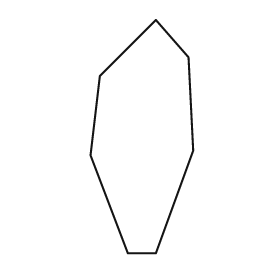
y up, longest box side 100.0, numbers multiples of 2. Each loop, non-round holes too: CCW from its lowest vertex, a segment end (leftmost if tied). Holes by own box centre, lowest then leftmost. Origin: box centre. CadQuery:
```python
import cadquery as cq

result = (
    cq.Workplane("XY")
    .moveTo(-6.0, -50.0)
    .lineTo(6.0, -50.0)
    .lineTo(22.0, -6.0)
    .lineTo(20.0, 34.0)
    .lineTo(6.0, 50.0)
    .lineTo(-18.0, 26.0)
    .lineTo(-22.0, -8.0)
    .close()
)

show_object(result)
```